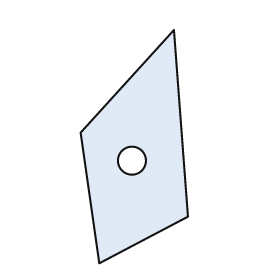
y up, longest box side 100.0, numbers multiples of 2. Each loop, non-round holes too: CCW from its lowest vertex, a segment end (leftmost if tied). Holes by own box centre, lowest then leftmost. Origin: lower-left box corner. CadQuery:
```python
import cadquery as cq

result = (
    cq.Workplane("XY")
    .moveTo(8.0, 0.0)
    .lineTo(46.0, 20.0)
    .lineTo(40.0, 100.0)
    .lineTo(0.0, 56.0)
    .close()
    .moveTo(22.0, 44.0)
    .circle(6.0)
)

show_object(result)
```